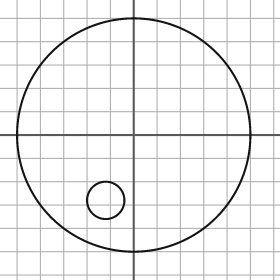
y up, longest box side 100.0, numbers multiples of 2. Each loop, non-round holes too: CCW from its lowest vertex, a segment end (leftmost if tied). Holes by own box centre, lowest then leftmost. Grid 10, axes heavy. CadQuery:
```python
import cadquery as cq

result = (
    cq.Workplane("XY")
    .moveTo(0.0, 0.0)
    .circle(50.0)
    .moveTo(-12.0, -28.0)
    .circle(8.0)
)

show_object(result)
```